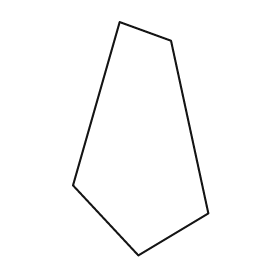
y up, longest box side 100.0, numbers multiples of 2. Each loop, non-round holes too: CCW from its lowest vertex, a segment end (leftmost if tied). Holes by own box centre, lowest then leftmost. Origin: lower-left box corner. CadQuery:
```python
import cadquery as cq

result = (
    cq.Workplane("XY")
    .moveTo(28.0, 0.0)
    .lineTo(58.0, 18.0)
    .lineTo(42.0, 92.0)
    .lineTo(20.0, 100.0)
    .lineTo(0.0, 30.0)
    .close()
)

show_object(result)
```